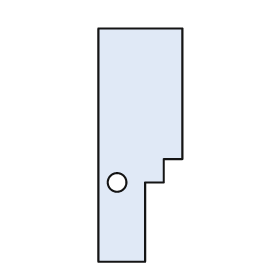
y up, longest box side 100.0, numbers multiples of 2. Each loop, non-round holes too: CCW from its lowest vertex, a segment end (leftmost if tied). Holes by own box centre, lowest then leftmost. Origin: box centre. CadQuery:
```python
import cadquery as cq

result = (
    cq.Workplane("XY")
    .moveTo(-18.0, -50.0)
    .lineTo(2.0, -50.0)
    .lineTo(2.0, -16.0)
    .lineTo(10.0, -16.0)
    .lineTo(10.0, -6.0)
    .lineTo(18.0, -6.0)
    .lineTo(18.0, 50.0)
    .lineTo(-18.0, 50.0)
    .close()
    .moveTo(-10.0, -16.0)
    .circle(4.0)
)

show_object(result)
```